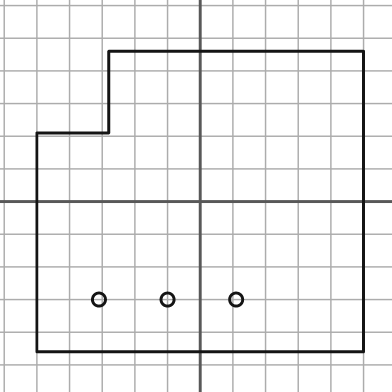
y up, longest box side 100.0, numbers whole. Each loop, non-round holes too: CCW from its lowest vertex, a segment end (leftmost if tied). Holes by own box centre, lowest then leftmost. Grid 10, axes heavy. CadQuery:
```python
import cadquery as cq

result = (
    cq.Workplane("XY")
    .moveTo(-50.0, -46.0)
    .lineTo(50.0, -46.0)
    .lineTo(50.0, 46.0)
    .lineTo(-28.0, 46.0)
    .lineTo(-28.0, 21.0)
    .lineTo(-50.0, 21.0)
    .close()
    .moveTo(-31.0, -30.0)
    .circle(2.0)
    .moveTo(-10.0, -30.0)
    .circle(2.0)
    .moveTo(11.0, -30.0)
    .circle(2.0)
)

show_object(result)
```